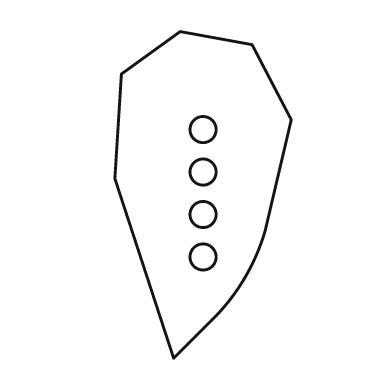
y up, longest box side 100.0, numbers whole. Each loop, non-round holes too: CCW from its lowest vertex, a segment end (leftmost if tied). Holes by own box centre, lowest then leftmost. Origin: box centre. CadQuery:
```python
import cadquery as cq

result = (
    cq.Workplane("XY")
    .moveTo(-9.0, -50.0)
    .lineTo(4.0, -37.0)
    .threePointArc((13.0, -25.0), (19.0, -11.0))
    .lineTo(27.0, 23.0)
    .lineTo(15.0, 46.0)
    .lineTo(-7.0, 50.0)
    .lineTo(-25.0, 37.0)
    .lineTo(-27.0, 5.0)
    .close()
    .moveTo(0.0, -19.0)
    .circle(4.0)
    .moveTo(0.0, -6.0)
    .circle(4.0)
    .moveTo(0.0, 7.0)
    .circle(4.0)
    .moveTo(0.0, 20.0)
    .circle(4.0)
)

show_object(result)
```